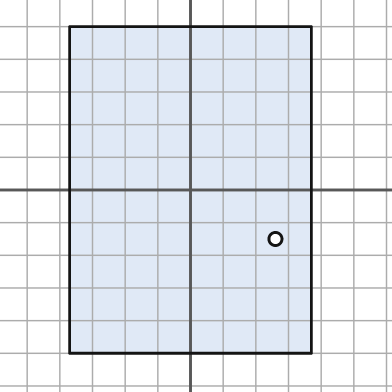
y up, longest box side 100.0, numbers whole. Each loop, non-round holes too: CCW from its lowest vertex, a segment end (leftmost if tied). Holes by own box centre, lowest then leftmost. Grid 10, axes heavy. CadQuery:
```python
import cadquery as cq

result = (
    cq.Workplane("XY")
    .moveTo(-37.0, -50.0)
    .lineTo(37.0, -50.0)
    .lineTo(37.0, 50.0)
    .lineTo(-37.0, 50.0)
    .close()
    .moveTo(26.0, -15.0)
    .circle(2.0)
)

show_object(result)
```